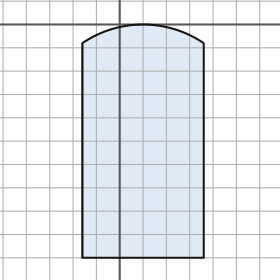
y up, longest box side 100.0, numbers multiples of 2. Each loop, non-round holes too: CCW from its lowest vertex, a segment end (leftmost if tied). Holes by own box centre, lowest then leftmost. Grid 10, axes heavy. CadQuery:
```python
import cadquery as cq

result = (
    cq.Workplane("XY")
    .moveTo(-16.0, -100.0)
    .lineTo(36.0, -100.0)
    .lineTo(36.0, -8.0)
    .threePointArc((10.0, 0.0), (-16.0, -8.0))
    .close()
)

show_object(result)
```